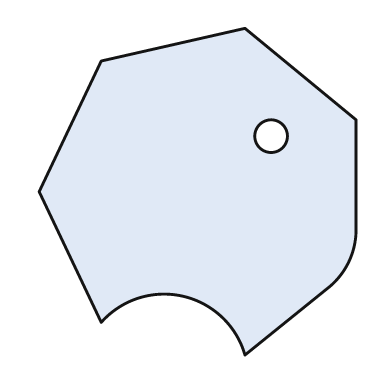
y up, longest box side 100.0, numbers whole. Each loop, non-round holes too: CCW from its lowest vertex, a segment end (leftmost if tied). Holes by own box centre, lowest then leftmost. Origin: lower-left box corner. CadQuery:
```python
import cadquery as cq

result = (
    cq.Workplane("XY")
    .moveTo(63.0, 0.0)
    .lineTo(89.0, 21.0)
    .threePointArc((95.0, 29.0), (97.0, 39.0))
    .lineTo(97.0, 72.0)
    .lineTo(63.0, 100.0)
    .lineTo(19.0, 90.0)
    .lineTo(0.0, 50.0)
    .lineTo(19.0, 10.0)
    .threePointArc((44.0, 18.0), (63.0, 0.0))
    .close()
    .moveTo(71.0, 67.0)
    .circle(5.0)
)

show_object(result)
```